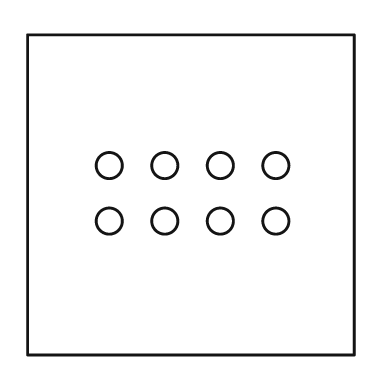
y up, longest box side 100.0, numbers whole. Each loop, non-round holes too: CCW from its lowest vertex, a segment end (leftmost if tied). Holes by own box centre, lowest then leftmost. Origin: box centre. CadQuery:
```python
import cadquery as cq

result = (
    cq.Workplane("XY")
    .moveTo(-50.0, -49.0)
    .lineTo(50.0, -49.0)
    .lineTo(50.0, 49.0)
    .lineTo(-50.0, 49.0)
    .close()
    .moveTo(-25.0, -8.0)
    .circle(4.0)
    .moveTo(-8.0, -8.0)
    .circle(4.0)
    .moveTo(9.0, -8.0)
    .circle(4.0)
    .moveTo(26.0, -8.0)
    .circle(4.0)
    .moveTo(-25.0, 9.0)
    .circle(4.0)
    .moveTo(-8.0, 9.0)
    .circle(4.0)
    .moveTo(9.0, 9.0)
    .circle(4.0)
    .moveTo(26.0, 9.0)
    .circle(4.0)
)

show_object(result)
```